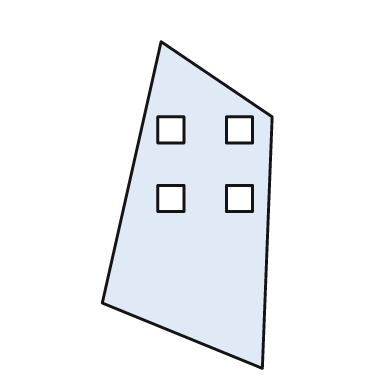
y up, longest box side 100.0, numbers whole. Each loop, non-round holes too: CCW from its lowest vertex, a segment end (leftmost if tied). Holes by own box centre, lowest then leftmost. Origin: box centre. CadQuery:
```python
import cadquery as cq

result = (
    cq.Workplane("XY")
    .moveTo(23.0, -50.0)
    .lineTo(26.0, 27.0)
    .lineTo(-8.0, 50.0)
    .lineTo(-26.0, -30.0)
    .close()
    .moveTo(-9.0, -2.0)
    .lineTo(-1.0, -2.0)
    .lineTo(-1.0, 6.0)
    .lineTo(-9.0, 6.0)
    .close()
    .moveTo(12.0, -2.0)
    .lineTo(20.0, -2.0)
    .lineTo(20.0, 6.0)
    .lineTo(12.0, 6.0)
    .close()
    .moveTo(-9.0, 19.0)
    .lineTo(-1.0, 19.0)
    .lineTo(-1.0, 27.0)
    .lineTo(-9.0, 27.0)
    .close()
    .moveTo(12.0, 19.0)
    .lineTo(20.0, 19.0)
    .lineTo(20.0, 27.0)
    .lineTo(12.0, 27.0)
    .close()
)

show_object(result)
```